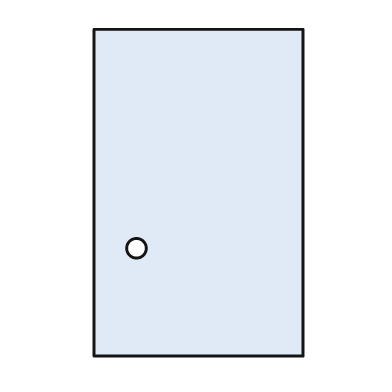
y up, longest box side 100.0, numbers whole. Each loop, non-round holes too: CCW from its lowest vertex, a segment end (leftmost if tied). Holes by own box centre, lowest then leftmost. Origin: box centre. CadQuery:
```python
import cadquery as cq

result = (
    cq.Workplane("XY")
    .moveTo(-32.0, -50.0)
    .lineTo(32.0, -50.0)
    .lineTo(32.0, 50.0)
    .lineTo(-32.0, 50.0)
    .close()
    .moveTo(-19.0, -17.0)
    .circle(3.0)
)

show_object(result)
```